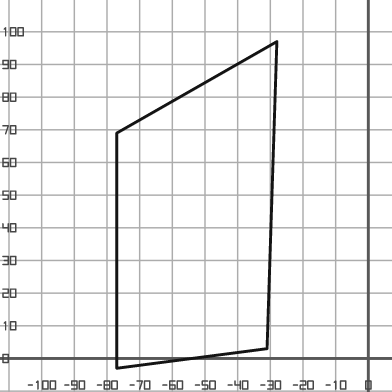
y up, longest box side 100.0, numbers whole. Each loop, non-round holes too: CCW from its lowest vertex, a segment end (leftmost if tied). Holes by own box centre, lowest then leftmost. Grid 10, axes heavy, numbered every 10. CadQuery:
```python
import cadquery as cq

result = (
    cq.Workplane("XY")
    .moveTo(-77.0, -3.0)
    .lineTo(-31.0, 3.0)
    .lineTo(-28.0, 97.0)
    .lineTo(-77.0, 69.0)
    .close()
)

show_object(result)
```